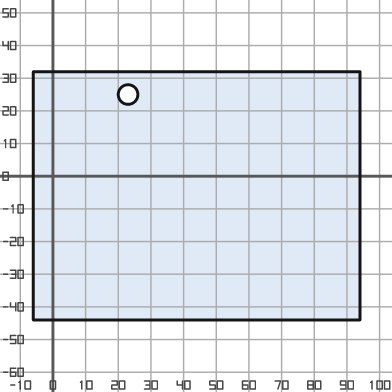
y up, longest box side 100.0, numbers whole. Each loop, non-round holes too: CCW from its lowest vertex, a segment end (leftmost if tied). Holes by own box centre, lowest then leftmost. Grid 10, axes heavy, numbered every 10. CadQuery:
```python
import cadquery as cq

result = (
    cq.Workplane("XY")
    .moveTo(-6.0, -44.0)
    .lineTo(94.0, -44.0)
    .lineTo(94.0, 32.0)
    .lineTo(-6.0, 32.0)
    .close()
    .moveTo(23.0, 25.0)
    .circle(3.0)
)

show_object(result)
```